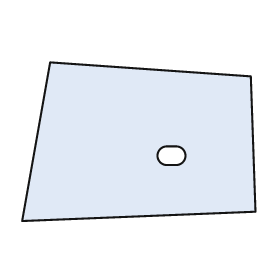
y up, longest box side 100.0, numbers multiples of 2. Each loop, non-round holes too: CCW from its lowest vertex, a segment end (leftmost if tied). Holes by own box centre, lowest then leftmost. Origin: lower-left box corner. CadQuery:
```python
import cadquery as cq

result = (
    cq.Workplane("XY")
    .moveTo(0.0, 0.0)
    .lineTo(100.0, 4.0)
    .lineTo(98.0, 62.0)
    .lineTo(12.0, 68.0)
    .close()
    .moveTo(62.0, 24.0)
    .lineTo(66.0, 24.0)
    .threePointArc((70.0, 28.0), (66.0, 32.0))
    .lineTo(62.0, 32.0)
    .threePointArc((58.0, 28.0), (62.0, 24.0))
    .close()
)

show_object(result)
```